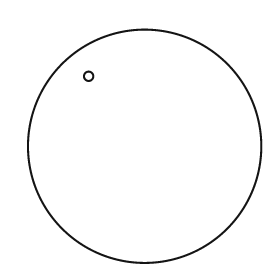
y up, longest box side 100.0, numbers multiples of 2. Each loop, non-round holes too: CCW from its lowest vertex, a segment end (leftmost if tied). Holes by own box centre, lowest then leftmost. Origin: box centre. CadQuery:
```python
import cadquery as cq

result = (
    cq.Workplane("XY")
    .moveTo(0.0, 0.0)
    .circle(50.0)
    .moveTo(-24.0, 30.0)
    .circle(2.0)
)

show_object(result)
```